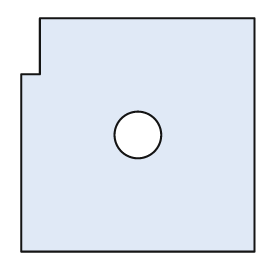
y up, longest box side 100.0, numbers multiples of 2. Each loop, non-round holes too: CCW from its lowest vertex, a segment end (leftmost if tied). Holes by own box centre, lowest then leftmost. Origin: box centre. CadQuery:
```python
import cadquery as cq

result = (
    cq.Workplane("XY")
    .moveTo(-50.0, -50.0)
    .lineTo(50.0, -50.0)
    .lineTo(50.0, 50.0)
    .lineTo(-42.0, 50.0)
    .lineTo(-42.0, 26.0)
    .lineTo(-50.0, 26.0)
    .close()
    .moveTo(0.0, 0.0)
    .circle(10.0)
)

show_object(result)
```